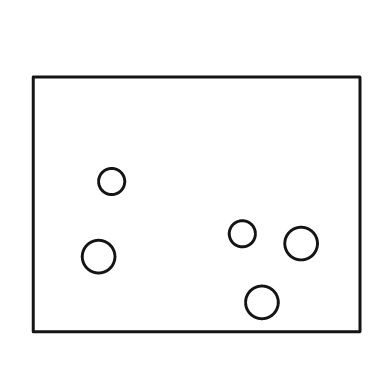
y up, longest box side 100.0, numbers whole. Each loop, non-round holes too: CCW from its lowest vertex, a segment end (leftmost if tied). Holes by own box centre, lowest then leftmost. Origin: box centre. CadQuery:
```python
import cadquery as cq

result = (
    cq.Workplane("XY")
    .moveTo(-50.0, -39.0)
    .lineTo(50.0, -39.0)
    .lineTo(50.0, 39.0)
    .lineTo(-50.0, 39.0)
    .close()
    .moveTo(20.0, -30.0)
    .circle(5.0)
    .moveTo(-30.0, -16.0)
    .circle(5.0)
    .moveTo(32.0, -12.0)
    .circle(5.0)
    .moveTo(14.0, -9.0)
    .circle(4.0)
    .moveTo(-26.0, 7.0)
    .circle(4.0)
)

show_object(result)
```